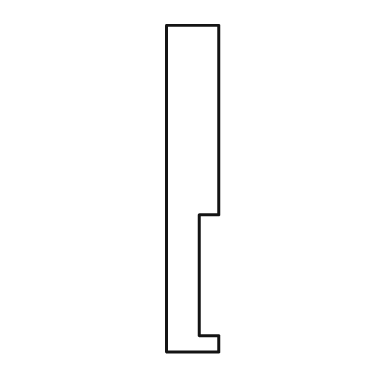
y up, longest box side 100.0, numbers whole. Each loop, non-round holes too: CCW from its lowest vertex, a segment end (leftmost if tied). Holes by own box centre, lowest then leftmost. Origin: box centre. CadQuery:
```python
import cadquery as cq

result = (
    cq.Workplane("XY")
    .moveTo(-8.0, -50.0)
    .lineTo(8.0, -50.0)
    .lineTo(8.0, -45.0)
    .lineTo(2.0, -45.0)
    .lineTo(2.0, -8.0)
    .lineTo(8.0, -8.0)
    .lineTo(8.0, 50.0)
    .lineTo(-8.0, 50.0)
    .close()
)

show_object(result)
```